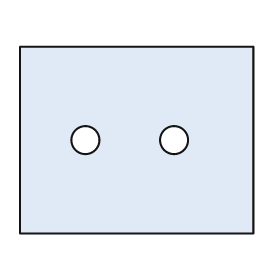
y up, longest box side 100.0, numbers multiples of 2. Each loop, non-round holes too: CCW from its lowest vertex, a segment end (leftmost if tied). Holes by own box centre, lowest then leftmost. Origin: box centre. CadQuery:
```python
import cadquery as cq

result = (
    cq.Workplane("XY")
    .moveTo(-50.0, -40.0)
    .lineTo(50.0, -40.0)
    .lineTo(50.0, 40.0)
    .lineTo(-50.0, 40.0)
    .close()
    .moveTo(-22.0, 0.0)
    .circle(6.0)
    .moveTo(16.0, 0.0)
    .circle(6.0)
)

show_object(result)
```